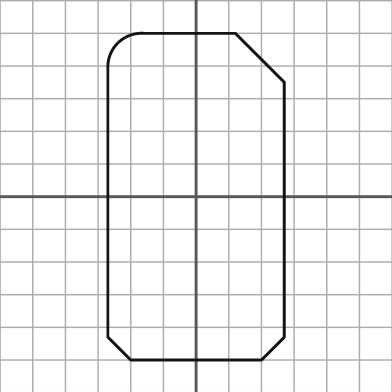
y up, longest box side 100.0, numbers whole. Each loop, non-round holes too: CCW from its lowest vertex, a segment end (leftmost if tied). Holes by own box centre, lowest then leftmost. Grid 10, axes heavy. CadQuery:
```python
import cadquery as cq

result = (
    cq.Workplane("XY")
    .moveTo(-20.0, -50.0)
    .lineTo(20.0, -50.0)
    .lineTo(27.0, -43.0)
    .lineTo(27.0, 35.0)
    .lineTo(12.0, 50.0)
    .lineTo(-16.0, 50.0)
    .threePointArc((-24.0, 47.0), (-27.0, 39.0))
    .lineTo(-27.0, -43.0)
    .close()
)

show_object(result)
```